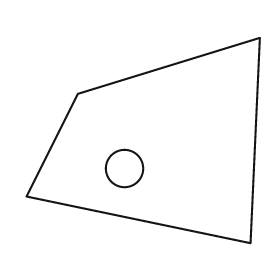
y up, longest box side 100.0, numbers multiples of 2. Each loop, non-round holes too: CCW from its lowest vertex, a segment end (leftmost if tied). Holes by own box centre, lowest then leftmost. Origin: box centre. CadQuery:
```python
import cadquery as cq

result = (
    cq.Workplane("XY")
    .moveTo(46.0, -44.0)
    .lineTo(50.0, 44.0)
    .lineTo(-28.0, 20.0)
    .lineTo(-50.0, -24.0)
    .close()
    .moveTo(-8.0, -12.0)
    .circle(8.0)
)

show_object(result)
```